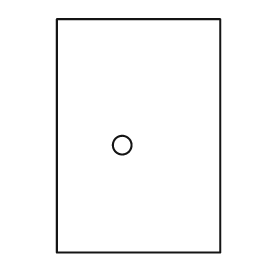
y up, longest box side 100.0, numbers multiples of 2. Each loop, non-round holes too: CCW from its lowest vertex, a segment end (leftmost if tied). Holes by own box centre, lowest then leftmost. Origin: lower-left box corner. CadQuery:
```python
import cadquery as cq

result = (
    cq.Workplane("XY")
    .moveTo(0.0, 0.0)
    .lineTo(70.0, 0.0)
    .lineTo(70.0, 100.0)
    .lineTo(0.0, 100.0)
    .close()
    .moveTo(28.0, 46.0)
    .circle(4.0)
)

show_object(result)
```